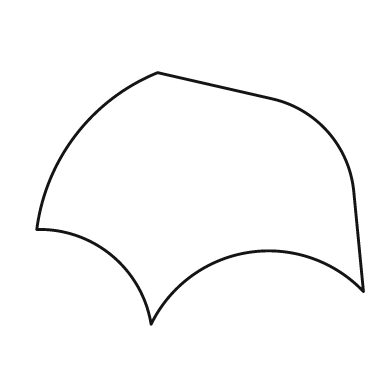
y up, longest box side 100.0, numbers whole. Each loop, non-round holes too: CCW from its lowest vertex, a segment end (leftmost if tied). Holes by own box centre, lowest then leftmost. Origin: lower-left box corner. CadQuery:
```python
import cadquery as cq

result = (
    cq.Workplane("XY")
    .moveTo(35.0, 0.0)
    .threePointArc((65.0, 22.0), (100.0, 10.0))
    .lineTo(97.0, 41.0)
    .threePointArc((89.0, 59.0), (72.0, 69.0))
    .lineTo(37.0, 77.0)
    .threePointArc((12.0, 58.0), (0.0, 29.0))
    .threePointArc((23.0, 21.0), (35.0, 0.0))
    .close()
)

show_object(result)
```